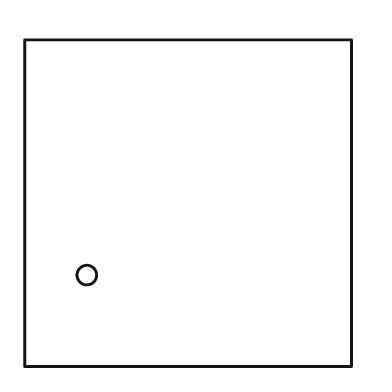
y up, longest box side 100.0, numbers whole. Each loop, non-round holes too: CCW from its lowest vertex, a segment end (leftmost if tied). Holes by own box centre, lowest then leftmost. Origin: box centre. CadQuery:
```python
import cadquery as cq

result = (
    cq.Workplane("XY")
    .moveTo(-50.0, -50.0)
    .lineTo(50.0, -50.0)
    .lineTo(50.0, 50.0)
    .lineTo(-50.0, 50.0)
    .close()
    .moveTo(-31.0, -22.0)
    .circle(3.0)
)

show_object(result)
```